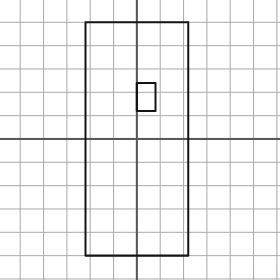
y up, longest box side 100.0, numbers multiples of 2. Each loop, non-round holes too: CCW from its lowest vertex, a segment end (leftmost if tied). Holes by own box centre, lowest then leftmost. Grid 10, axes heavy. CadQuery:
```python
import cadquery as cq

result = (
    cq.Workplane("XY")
    .moveTo(-22.0, -50.0)
    .lineTo(22.0, -50.0)
    .lineTo(22.0, 50.0)
    .lineTo(-22.0, 50.0)
    .close()
    .moveTo(0.0, 12.0)
    .lineTo(8.0, 12.0)
    .lineTo(8.0, 24.0)
    .lineTo(0.0, 24.0)
    .close()
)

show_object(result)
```